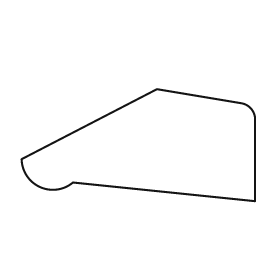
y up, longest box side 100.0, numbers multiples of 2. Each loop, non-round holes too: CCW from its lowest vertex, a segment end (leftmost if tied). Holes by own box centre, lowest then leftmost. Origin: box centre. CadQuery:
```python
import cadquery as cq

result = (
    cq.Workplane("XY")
    .moveTo(50.0, -24.0)
    .lineTo(50.0, 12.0)
    .threePointArc((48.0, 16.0), (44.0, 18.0))
    .lineTo(8.0, 24.0)
    .lineTo(-50.0, -6.0)
    .threePointArc((-42.0, -18.0), (-28.0, -16.0))
    .close()
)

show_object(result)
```